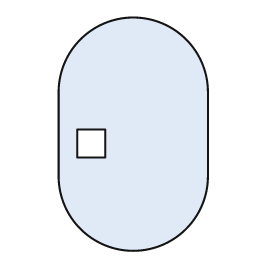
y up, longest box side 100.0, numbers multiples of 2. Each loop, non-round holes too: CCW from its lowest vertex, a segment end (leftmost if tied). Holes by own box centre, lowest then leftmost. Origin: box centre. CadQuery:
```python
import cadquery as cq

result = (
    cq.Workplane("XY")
    .moveTo(-32.0, -18.0)
    .threePointArc((0.0, -50.0), (32.0, -18.0))
    .lineTo(32.0, 18.0)
    .threePointArc((0.0, 50.0), (-32.0, 18.0))
    .close()
    .moveTo(-24.0, -10.0)
    .lineTo(-12.0, -10.0)
    .lineTo(-12.0, 2.0)
    .lineTo(-24.0, 2.0)
    .close()
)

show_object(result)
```